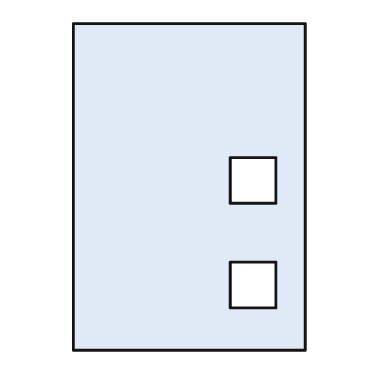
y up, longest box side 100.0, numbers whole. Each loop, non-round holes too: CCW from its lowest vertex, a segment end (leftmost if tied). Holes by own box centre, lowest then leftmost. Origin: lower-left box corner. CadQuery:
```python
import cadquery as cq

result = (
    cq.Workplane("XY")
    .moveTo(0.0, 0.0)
    .lineTo(71.0, 0.0)
    .lineTo(71.0, 100.0)
    .lineTo(0.0, 100.0)
    .close()
    .moveTo(48.0, 13.0)
    .lineTo(62.0, 13.0)
    .lineTo(62.0, 27.0)
    .lineTo(48.0, 27.0)
    .close()
    .moveTo(48.0, 45.0)
    .lineTo(62.0, 45.0)
    .lineTo(62.0, 59.0)
    .lineTo(48.0, 59.0)
    .close()
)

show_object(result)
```